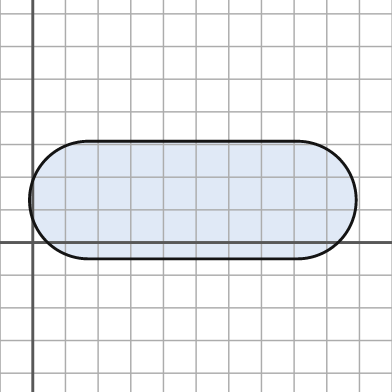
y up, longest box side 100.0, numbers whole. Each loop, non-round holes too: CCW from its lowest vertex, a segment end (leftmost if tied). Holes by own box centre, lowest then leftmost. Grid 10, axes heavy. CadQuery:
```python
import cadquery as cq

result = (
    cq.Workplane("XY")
    .moveTo(17.0, -5.0)
    .lineTo(81.0, -5.0)
    .threePointArc((99.0, 13.0), (81.0, 31.0))
    .lineTo(17.0, 31.0)
    .threePointArc((-1.0, 13.0), (17.0, -5.0))
    .close()
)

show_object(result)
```